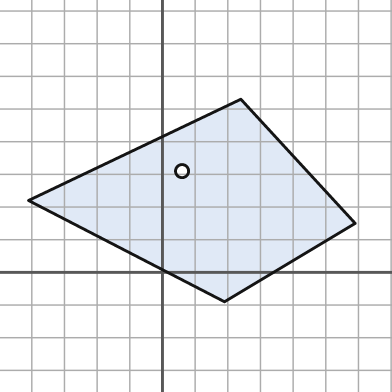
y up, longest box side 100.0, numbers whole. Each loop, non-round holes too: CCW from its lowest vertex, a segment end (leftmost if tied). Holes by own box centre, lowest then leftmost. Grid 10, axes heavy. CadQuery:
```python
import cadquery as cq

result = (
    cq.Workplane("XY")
    .moveTo(19.0, -9.0)
    .lineTo(59.0, 15.0)
    .lineTo(24.0, 53.0)
    .lineTo(-41.0, 22.0)
    .close()
    .moveTo(6.0, 31.0)
    .circle(2.0)
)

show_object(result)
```